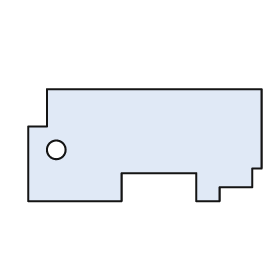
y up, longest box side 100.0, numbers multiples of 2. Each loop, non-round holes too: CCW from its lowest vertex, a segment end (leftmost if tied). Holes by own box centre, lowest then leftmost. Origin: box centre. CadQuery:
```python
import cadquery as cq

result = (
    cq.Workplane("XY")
    .moveTo(-50.0, -24.0)
    .lineTo(-10.0, -24.0)
    .lineTo(-10.0, -12.0)
    .lineTo(22.0, -12.0)
    .lineTo(22.0, -24.0)
    .lineTo(32.0, -24.0)
    .lineTo(32.0, -18.0)
    .lineTo(46.0, -18.0)
    .lineTo(46.0, -10.0)
    .lineTo(50.0, -10.0)
    .lineTo(50.0, 24.0)
    .lineTo(-42.0, 24.0)
    .lineTo(-42.0, 8.0)
    .lineTo(-50.0, 8.0)
    .close()
    .moveTo(-38.0, -2.0)
    .circle(4.0)
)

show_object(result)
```